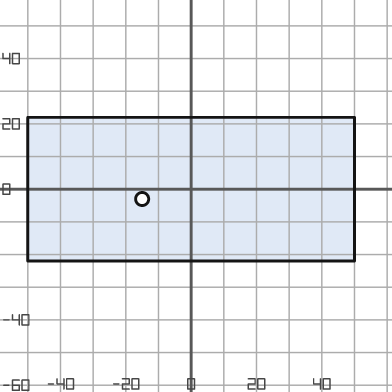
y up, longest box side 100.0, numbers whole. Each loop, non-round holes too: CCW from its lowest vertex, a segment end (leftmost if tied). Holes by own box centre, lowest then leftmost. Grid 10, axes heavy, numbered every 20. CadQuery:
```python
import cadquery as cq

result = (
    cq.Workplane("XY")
    .moveTo(-50.0, -22.0)
    .lineTo(50.0, -22.0)
    .lineTo(50.0, 22.0)
    .lineTo(-50.0, 22.0)
    .close()
    .moveTo(-15.0, -3.0)
    .circle(2.0)
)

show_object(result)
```